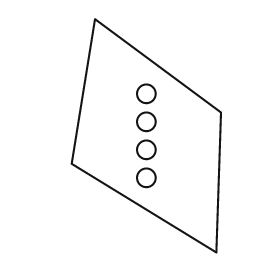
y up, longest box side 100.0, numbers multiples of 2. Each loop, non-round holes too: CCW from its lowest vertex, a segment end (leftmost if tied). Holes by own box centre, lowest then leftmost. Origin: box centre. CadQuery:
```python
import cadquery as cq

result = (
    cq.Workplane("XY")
    .moveTo(30.0, -50.0)
    .lineTo(32.0, 10.0)
    .lineTo(-22.0, 50.0)
    .lineTo(-32.0, -12.0)
    .close()
    .moveTo(0.0, -18.0)
    .circle(4.0)
    .moveTo(0.0, -6.0)
    .circle(4.0)
    .moveTo(0.0, 6.0)
    .circle(4.0)
    .moveTo(0.0, 18.0)
    .circle(4.0)
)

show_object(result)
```